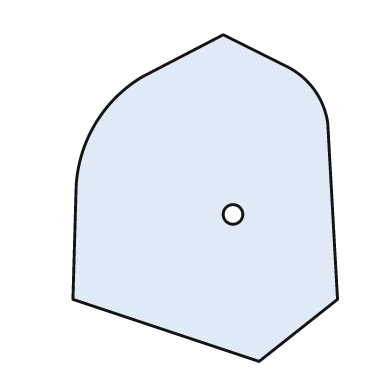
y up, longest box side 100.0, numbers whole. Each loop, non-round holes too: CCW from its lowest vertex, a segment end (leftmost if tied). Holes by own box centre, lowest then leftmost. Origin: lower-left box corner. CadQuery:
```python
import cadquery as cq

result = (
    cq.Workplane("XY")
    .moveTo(57.0, 0.0)
    .lineTo(81.0, 19.0)
    .lineTo(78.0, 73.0)
    .threePointArc((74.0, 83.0), (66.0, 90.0))
    .lineTo(46.0, 100.0)
    .lineTo(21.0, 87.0)
    .threePointArc((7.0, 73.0), (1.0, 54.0))
    .lineTo(0.0, 19.0)
    .close()
    .moveTo(49.0, 45.0)
    .circle(3.0)
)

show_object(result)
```